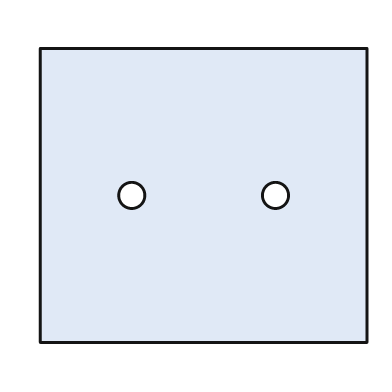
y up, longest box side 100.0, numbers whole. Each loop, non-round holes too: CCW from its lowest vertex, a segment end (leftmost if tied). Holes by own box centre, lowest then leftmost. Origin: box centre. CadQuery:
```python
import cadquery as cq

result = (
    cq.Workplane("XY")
    .moveTo(-50.0, -45.0)
    .lineTo(50.0, -45.0)
    .lineTo(50.0, 45.0)
    .lineTo(-50.0, 45.0)
    .close()
    .moveTo(-22.0, 0.0)
    .circle(4.0)
    .moveTo(22.0, 0.0)
    .circle(4.0)
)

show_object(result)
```